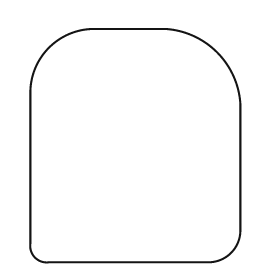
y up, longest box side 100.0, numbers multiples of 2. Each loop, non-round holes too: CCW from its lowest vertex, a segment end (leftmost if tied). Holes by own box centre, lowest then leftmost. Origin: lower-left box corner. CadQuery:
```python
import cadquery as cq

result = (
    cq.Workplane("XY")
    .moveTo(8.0, 0.0)
    .lineTo(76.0, 0.0)
    .threePointArc((86.0, 4.0), (90.0, 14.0))
    .lineTo(90.0, 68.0)
    .threePointArc((80.0, 90.0), (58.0, 100.0))
    .lineTo(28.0, 100.0)
    .threePointArc((8.0, 92.0), (0.0, 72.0))
    .lineTo(0.0, 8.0)
    .threePointArc((2.0, 2.0), (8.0, 0.0))
    .close()
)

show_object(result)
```